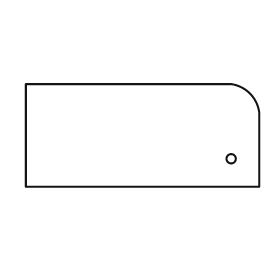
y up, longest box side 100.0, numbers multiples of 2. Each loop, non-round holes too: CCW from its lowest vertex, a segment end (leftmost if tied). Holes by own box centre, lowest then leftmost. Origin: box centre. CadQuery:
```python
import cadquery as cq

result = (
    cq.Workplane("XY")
    .moveTo(-50.0, -22.0)
    .lineTo(50.0, -22.0)
    .lineTo(50.0, 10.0)
    .threePointArc((46.0, 18.0), (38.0, 22.0))
    .lineTo(-50.0, 22.0)
    .close()
    .moveTo(38.0, -10.0)
    .circle(2.0)
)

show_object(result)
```